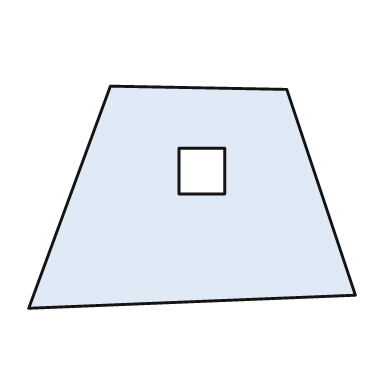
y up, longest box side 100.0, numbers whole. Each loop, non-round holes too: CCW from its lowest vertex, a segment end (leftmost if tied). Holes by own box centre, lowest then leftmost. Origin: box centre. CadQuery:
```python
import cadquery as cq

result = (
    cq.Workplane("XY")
    .moveTo(-50.0, -34.0)
    .lineTo(50.0, -30.0)
    .lineTo(29.0, 33.0)
    .lineTo(-25.0, 34.0)
    .close()
    .moveTo(-4.0, 1.0)
    .lineTo(10.0, 1.0)
    .lineTo(10.0, 15.0)
    .lineTo(-4.0, 15.0)
    .close()
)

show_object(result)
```